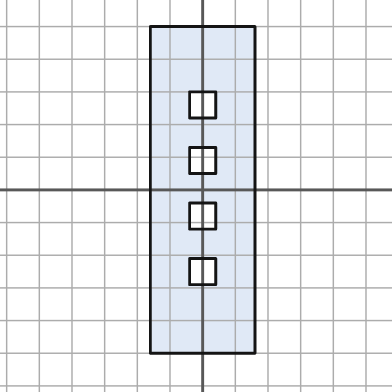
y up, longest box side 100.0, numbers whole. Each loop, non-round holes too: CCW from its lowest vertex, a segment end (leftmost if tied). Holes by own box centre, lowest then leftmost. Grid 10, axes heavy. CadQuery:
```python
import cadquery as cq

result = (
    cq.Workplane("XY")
    .moveTo(-16.0, -50.0)
    .lineTo(16.0, -50.0)
    .lineTo(16.0, 50.0)
    .lineTo(-16.0, 50.0)
    .close()
    .moveTo(-4.0, -29.0)
    .lineTo(4.0, -29.0)
    .lineTo(4.0, -21.0)
    .lineTo(-4.0, -21.0)
    .close()
    .moveTo(-4.0, -12.0)
    .lineTo(4.0, -12.0)
    .lineTo(4.0, -4.0)
    .lineTo(-4.0, -4.0)
    .close()
    .moveTo(-4.0, 5.0)
    .lineTo(4.0, 5.0)
    .lineTo(4.0, 13.0)
    .lineTo(-4.0, 13.0)
    .close()
    .moveTo(-4.0, 22.0)
    .lineTo(4.0, 22.0)
    .lineTo(4.0, 30.0)
    .lineTo(-4.0, 30.0)
    .close()
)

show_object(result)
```